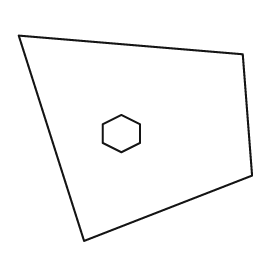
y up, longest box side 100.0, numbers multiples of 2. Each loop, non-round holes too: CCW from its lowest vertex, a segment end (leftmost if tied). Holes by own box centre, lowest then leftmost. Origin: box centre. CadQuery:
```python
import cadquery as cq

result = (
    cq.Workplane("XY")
    .moveTo(-22.0, -44.0)
    .lineTo(50.0, -16.0)
    .lineTo(46.0, 36.0)
    .lineTo(-50.0, 44.0)
    .close()
    .moveTo(-6.0, -6.0)
    .lineTo(2.0, -2.0)
    .lineTo(2.0, 6.0)
    .lineTo(-6.0, 10.0)
    .lineTo(-14.0, 6.0)
    .lineTo(-14.0, -2.0)
    .close()
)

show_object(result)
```